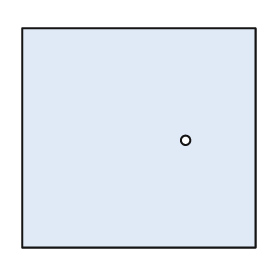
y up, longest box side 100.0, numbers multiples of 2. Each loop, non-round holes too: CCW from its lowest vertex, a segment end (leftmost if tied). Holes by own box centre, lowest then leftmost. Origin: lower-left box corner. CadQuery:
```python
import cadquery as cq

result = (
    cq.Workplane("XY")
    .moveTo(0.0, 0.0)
    .lineTo(100.0, 0.0)
    .lineTo(100.0, 94.0)
    .lineTo(0.0, 94.0)
    .close()
    .moveTo(70.0, 46.0)
    .circle(2.0)
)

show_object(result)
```